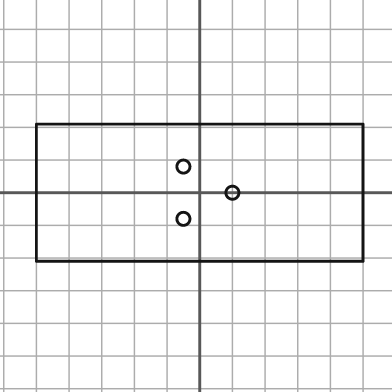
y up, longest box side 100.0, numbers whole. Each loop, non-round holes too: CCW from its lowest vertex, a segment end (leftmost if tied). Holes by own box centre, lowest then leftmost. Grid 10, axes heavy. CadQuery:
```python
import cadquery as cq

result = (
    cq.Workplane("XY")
    .moveTo(-50.0, -21.0)
    .lineTo(50.0, -21.0)
    .lineTo(50.0, 21.0)
    .lineTo(-50.0, 21.0)
    .close()
    .moveTo(-5.0, -8.0)
    .circle(2.0)
    .moveTo(10.0, 0.0)
    .circle(2.0)
    .moveTo(-5.0, 8.0)
    .circle(2.0)
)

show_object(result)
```